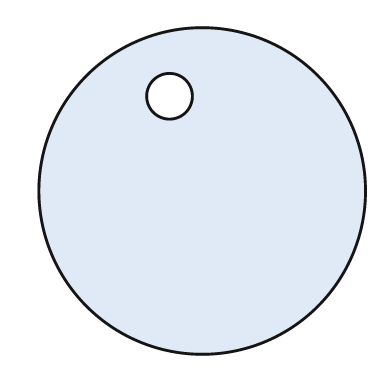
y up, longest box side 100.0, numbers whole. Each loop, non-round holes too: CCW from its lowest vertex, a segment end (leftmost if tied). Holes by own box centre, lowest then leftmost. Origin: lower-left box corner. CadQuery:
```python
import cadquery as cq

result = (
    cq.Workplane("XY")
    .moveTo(50.0, 50.0)
    .circle(50.0)
    .moveTo(40.0, 79.0)
    .circle(7.0)
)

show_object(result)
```